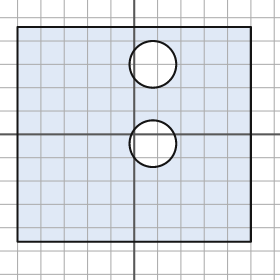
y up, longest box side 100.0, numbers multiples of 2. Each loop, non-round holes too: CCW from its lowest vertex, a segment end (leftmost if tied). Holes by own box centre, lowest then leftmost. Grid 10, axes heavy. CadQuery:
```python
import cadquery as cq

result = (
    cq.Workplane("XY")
    .moveTo(-50.0, -46.0)
    .lineTo(50.0, -46.0)
    .lineTo(50.0, 46.0)
    .lineTo(-50.0, 46.0)
    .close()
    .moveTo(8.0, -4.0)
    .circle(10.0)
    .moveTo(8.0, 30.0)
    .circle(10.0)
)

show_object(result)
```